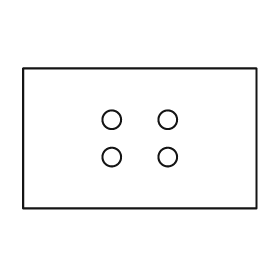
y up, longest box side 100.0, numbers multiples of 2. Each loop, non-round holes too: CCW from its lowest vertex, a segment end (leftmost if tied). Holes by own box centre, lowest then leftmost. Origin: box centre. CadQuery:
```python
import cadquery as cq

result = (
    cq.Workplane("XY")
    .moveTo(-50.0, -30.0)
    .lineTo(50.0, -30.0)
    .lineTo(50.0, 30.0)
    .lineTo(-50.0, 30.0)
    .close()
    .moveTo(-12.0, -8.0)
    .circle(4.0)
    .moveTo(12.0, -8.0)
    .circle(4.0)
    .moveTo(-12.0, 8.0)
    .circle(4.0)
    .moveTo(12.0, 8.0)
    .circle(4.0)
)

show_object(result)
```